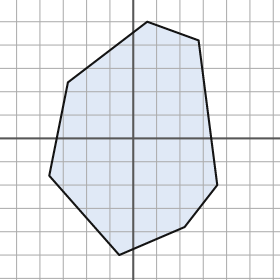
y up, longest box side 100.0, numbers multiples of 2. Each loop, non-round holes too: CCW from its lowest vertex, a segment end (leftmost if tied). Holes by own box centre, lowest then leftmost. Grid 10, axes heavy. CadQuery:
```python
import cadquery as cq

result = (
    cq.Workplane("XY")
    .moveTo(-6.0, -50.0)
    .lineTo(22.0, -38.0)
    .lineTo(36.0, -20.0)
    .lineTo(28.0, 42.0)
    .lineTo(6.0, 50.0)
    .lineTo(-28.0, 24.0)
    .lineTo(-36.0, -16.0)
    .close()
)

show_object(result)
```